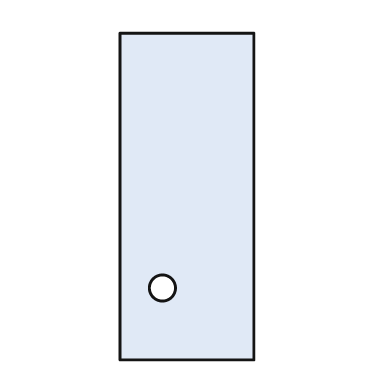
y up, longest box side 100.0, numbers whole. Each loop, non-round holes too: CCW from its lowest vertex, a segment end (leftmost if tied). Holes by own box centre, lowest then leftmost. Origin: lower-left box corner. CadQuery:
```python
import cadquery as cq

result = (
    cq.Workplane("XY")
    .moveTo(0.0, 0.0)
    .lineTo(41.0, 0.0)
    .lineTo(41.0, 100.0)
    .lineTo(0.0, 100.0)
    .close()
    .moveTo(13.0, 22.0)
    .circle(4.0)
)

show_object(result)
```